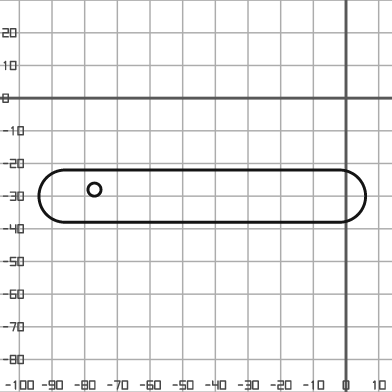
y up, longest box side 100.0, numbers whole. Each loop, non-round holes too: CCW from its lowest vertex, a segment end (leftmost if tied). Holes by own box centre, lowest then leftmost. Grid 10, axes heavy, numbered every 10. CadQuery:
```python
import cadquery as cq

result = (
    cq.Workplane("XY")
    .moveTo(-86.0, -38.0)
    .lineTo(-2.0, -38.0)
    .threePointArc((6.0, -30.0), (-2.0, -22.0))
    .lineTo(-86.0, -22.0)
    .threePointArc((-94.0, -30.0), (-86.0, -38.0))
    .close()
    .moveTo(-77.0, -28.0)
    .circle(2.0)
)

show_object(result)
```